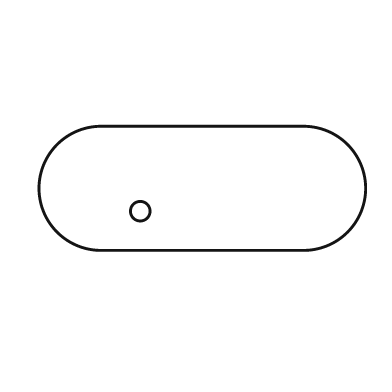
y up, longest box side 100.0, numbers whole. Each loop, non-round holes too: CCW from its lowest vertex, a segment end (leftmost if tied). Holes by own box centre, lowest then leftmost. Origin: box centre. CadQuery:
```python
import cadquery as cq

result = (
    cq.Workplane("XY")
    .moveTo(-31.0, -19.0)
    .lineTo(31.0, -19.0)
    .threePointArc((50.0, 0.0), (31.0, 19.0))
    .lineTo(-31.0, 19.0)
    .threePointArc((-50.0, 0.0), (-31.0, -19.0))
    .close()
    .moveTo(-19.0, -7.0)
    .circle(3.0)
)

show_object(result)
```